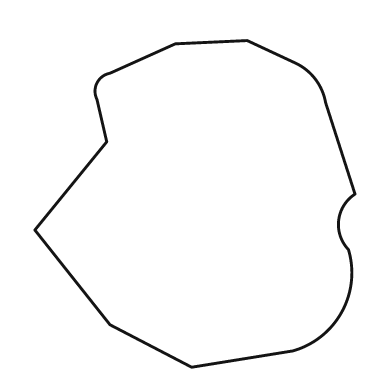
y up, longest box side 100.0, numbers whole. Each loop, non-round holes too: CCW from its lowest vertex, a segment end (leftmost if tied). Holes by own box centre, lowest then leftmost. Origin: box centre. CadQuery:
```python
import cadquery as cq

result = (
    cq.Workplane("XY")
    .moveTo(-1.0, -50.0)
    .lineTo(30.0, -45.0)
    .threePointArc((45.0, -33.0), (47.0, -14.0))
    .threePointArc((44.0, -5.0), (49.0, 3.0))
    .lineTo(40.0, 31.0)
    .threePointArc((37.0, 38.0), (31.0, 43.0))
    .lineTo(16.0, 50.0)
    .lineTo(-6.0, 49.0)
    .lineTo(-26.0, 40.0)
    .threePointArc((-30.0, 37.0), (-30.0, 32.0))
    .lineTo(-27.0, 19.0)
    .lineTo(-49.0, -8.0)
    .lineTo(-26.0, -37.0)
    .close()
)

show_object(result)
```